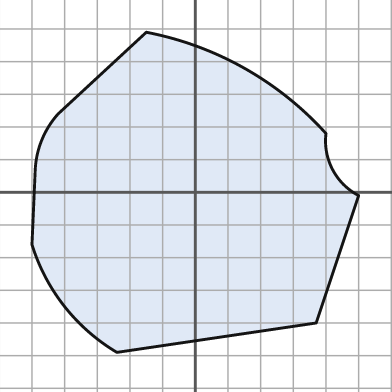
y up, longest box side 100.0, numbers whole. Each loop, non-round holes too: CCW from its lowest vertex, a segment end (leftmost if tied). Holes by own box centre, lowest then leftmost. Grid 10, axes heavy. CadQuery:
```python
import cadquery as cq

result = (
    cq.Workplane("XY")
    .moveTo(-24.0, -49.0)
    .lineTo(37.0, -40.0)
    .lineTo(50.0, -1.0)
    .threePointArc((42.0, 7.0), (40.0, 18.0))
    .threePointArc((15.0, 38.0), (-15.0, 49.0))
    .lineTo(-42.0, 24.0)
    .threePointArc((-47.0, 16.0), (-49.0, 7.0))
    .lineTo(-50.0, -16.0)
    .threePointArc((-40.0, -35.0), (-24.0, -49.0))
    .close()
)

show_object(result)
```